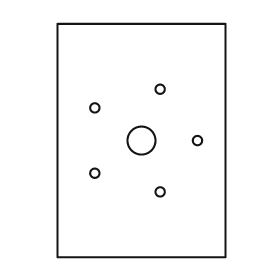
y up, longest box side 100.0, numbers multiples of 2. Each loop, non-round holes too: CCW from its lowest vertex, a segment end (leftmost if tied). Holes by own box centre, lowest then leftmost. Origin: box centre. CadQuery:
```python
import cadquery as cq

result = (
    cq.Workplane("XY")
    .moveTo(-36.0, -50.0)
    .lineTo(36.0, -50.0)
    .lineTo(36.0, 50.0)
    .lineTo(-36.0, 50.0)
    .close()
    .moveTo(8.0, -22.0)
    .circle(2.0)
    .moveTo(-20.0, -14.0)
    .circle(2.0)
    .moveTo(0.0, 0.0)
    .circle(6.0)
    .moveTo(24.0, 0.0)
    .circle(2.0)
    .moveTo(-20.0, 14.0)
    .circle(2.0)
    .moveTo(8.0, 22.0)
    .circle(2.0)
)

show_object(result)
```